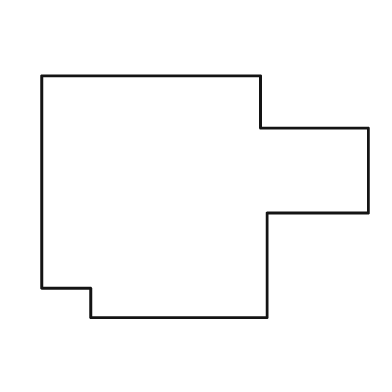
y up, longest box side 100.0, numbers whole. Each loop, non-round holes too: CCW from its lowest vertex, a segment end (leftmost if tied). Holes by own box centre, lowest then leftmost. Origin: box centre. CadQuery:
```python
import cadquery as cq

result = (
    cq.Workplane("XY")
    .moveTo(-35.0, -37.0)
    .lineTo(19.0, -37.0)
    .lineTo(19.0, -5.0)
    .lineTo(50.0, -5.0)
    .lineTo(50.0, 21.0)
    .lineTo(17.0, 21.0)
    .lineTo(17.0, 37.0)
    .lineTo(-50.0, 37.0)
    .lineTo(-50.0, -28.0)
    .lineTo(-35.0, -28.0)
    .close()
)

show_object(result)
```